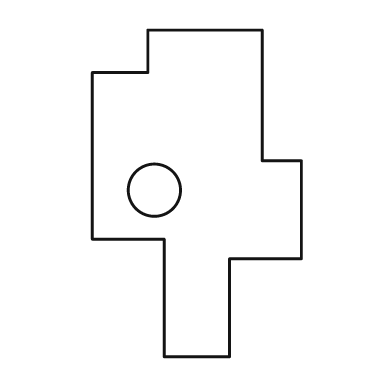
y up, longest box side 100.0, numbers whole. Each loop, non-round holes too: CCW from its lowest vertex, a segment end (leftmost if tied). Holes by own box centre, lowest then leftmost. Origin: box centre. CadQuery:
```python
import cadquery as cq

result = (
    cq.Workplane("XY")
    .moveTo(-10.0, -50.0)
    .lineTo(10.0, -50.0)
    .lineTo(10.0, -20.0)
    .lineTo(32.0, -20.0)
    .lineTo(32.0, 10.0)
    .lineTo(20.0, 10.0)
    .lineTo(20.0, 50.0)
    .lineTo(-15.0, 50.0)
    .lineTo(-15.0, 37.0)
    .lineTo(-32.0, 37.0)
    .lineTo(-32.0, -14.0)
    .lineTo(-10.0, -14.0)
    .close()
    .moveTo(-13.0, 1.0)
    .circle(8.0)
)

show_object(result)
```